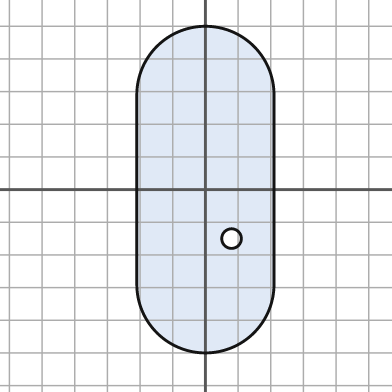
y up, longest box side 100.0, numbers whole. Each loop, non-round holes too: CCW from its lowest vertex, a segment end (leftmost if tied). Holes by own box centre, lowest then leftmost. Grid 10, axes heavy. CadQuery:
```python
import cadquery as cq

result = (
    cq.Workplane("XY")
    .moveTo(-21.0, -29.0)
    .threePointArc((0.0, -50.0), (21.0, -29.0))
    .lineTo(21.0, 29.0)
    .threePointArc((0.0, 50.0), (-21.0, 29.0))
    .close()
    .moveTo(8.0, -15.0)
    .circle(3.0)
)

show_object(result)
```